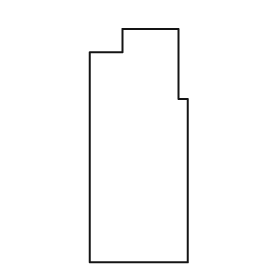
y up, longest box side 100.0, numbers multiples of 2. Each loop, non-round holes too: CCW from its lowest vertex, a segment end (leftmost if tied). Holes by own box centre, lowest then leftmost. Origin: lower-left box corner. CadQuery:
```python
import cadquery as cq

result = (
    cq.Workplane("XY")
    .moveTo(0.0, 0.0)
    .lineTo(42.0, 0.0)
    .lineTo(42.0, 70.0)
    .lineTo(38.0, 70.0)
    .lineTo(38.0, 100.0)
    .lineTo(14.0, 100.0)
    .lineTo(14.0, 90.0)
    .lineTo(0.0, 90.0)
    .close()
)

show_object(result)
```